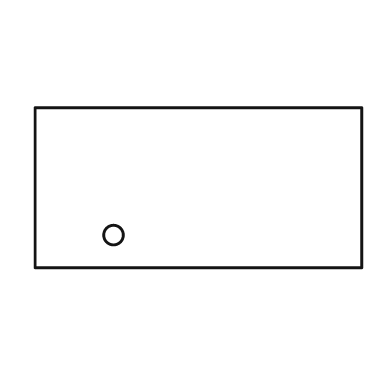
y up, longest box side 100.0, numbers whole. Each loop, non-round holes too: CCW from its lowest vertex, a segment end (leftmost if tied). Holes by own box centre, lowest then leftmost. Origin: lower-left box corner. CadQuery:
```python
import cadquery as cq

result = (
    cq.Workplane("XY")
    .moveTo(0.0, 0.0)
    .lineTo(100.0, 0.0)
    .lineTo(100.0, 49.0)
    .lineTo(0.0, 49.0)
    .close()
    .moveTo(24.0, 10.0)
    .circle(3.0)
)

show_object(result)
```